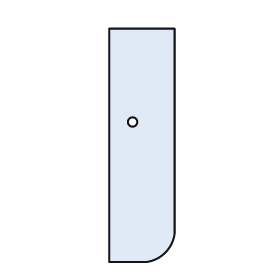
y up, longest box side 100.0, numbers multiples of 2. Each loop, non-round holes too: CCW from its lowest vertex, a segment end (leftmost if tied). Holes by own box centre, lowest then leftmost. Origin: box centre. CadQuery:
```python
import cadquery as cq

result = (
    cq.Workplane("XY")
    .moveTo(-14.0, -50.0)
    .lineTo(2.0, -50.0)
    .threePointArc((10.0, -46.0), (14.0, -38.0))
    .lineTo(14.0, 50.0)
    .lineTo(-14.0, 50.0)
    .close()
    .moveTo(-4.0, 10.0)
    .circle(2.0)
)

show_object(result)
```